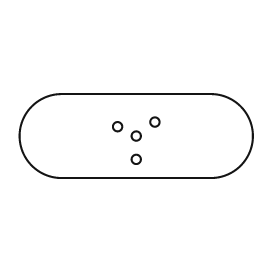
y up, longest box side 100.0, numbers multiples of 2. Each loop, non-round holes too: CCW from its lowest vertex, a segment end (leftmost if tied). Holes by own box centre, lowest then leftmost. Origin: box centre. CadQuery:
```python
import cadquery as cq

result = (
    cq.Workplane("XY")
    .moveTo(-32.0, -18.0)
    .lineTo(32.0, -18.0)
    .threePointArc((50.0, 0.0), (32.0, 18.0))
    .lineTo(-32.0, 18.0)
    .threePointArc((-50.0, 0.0), (-32.0, -18.0))
    .close()
    .moveTo(0.0, -10.0)
    .circle(2.0)
    .moveTo(0.0, 0.0)
    .circle(2.0)
    .moveTo(-8.0, 4.0)
    .circle(2.0)
    .moveTo(8.0, 6.0)
    .circle(2.0)
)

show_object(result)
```